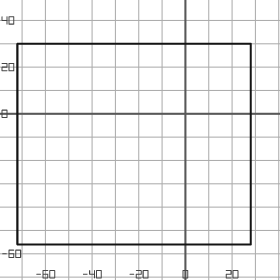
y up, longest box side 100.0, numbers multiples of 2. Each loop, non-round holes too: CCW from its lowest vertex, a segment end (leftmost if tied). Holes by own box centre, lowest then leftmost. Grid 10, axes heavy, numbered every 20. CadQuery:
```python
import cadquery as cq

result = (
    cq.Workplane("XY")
    .moveTo(-72.0, -56.0)
    .lineTo(28.0, -56.0)
    .lineTo(28.0, 30.0)
    .lineTo(-72.0, 30.0)
    .close()
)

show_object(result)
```